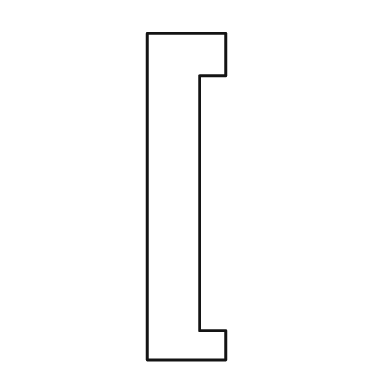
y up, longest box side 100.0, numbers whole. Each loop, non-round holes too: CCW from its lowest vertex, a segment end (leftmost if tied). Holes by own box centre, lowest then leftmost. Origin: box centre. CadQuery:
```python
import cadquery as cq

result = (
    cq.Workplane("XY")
    .moveTo(-12.0, -50.0)
    .lineTo(12.0, -50.0)
    .lineTo(12.0, -41.0)
    .lineTo(4.0, -41.0)
    .lineTo(4.0, 37.0)
    .lineTo(12.0, 37.0)
    .lineTo(12.0, 50.0)
    .lineTo(-12.0, 50.0)
    .close()
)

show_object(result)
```